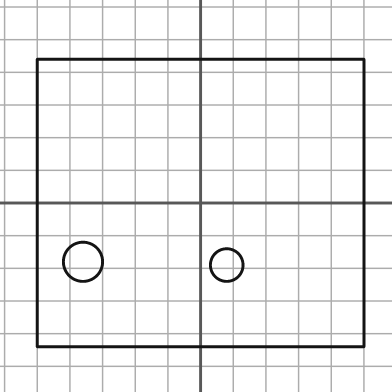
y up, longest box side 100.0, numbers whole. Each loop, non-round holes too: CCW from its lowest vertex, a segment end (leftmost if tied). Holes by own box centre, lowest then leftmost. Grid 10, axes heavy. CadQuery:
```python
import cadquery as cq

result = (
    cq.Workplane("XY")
    .moveTo(-50.0, -44.0)
    .lineTo(50.0, -44.0)
    .lineTo(50.0, 44.0)
    .lineTo(-50.0, 44.0)
    .close()
    .moveTo(8.0, -19.0)
    .circle(5.0)
    .moveTo(-36.0, -18.0)
    .circle(6.0)
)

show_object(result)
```